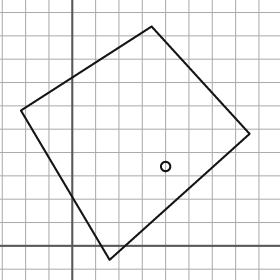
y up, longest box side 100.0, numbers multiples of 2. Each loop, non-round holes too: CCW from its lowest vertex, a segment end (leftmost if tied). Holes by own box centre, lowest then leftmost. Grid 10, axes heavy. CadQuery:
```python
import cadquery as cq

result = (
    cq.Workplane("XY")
    .moveTo(16.0, -6.0)
    .lineTo(76.0, 48.0)
    .lineTo(34.0, 94.0)
    .lineTo(-22.0, 58.0)
    .close()
    .moveTo(40.0, 34.0)
    .circle(2.0)
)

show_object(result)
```